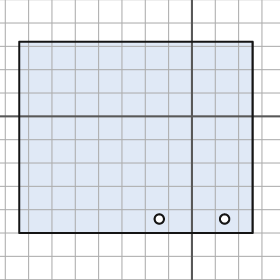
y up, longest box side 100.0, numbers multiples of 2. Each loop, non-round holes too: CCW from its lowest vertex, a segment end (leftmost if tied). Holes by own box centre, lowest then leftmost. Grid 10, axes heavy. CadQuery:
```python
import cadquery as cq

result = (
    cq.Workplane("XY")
    .moveTo(-74.0, -50.0)
    .lineTo(26.0, -50.0)
    .lineTo(26.0, 32.0)
    .lineTo(-74.0, 32.0)
    .close()
    .moveTo(-14.0, -44.0)
    .circle(2.0)
    .moveTo(14.0, -44.0)
    .circle(2.0)
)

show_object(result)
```